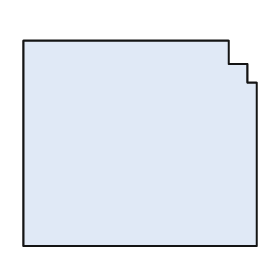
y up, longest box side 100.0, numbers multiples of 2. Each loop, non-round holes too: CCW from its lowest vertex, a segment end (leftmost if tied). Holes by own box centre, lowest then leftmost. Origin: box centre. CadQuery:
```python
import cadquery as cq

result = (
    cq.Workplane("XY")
    .moveTo(-50.0, -44.0)
    .lineTo(50.0, -44.0)
    .lineTo(50.0, 26.0)
    .lineTo(46.0, 26.0)
    .lineTo(46.0, 34.0)
    .lineTo(38.0, 34.0)
    .lineTo(38.0, 44.0)
    .lineTo(-50.0, 44.0)
    .close()
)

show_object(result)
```